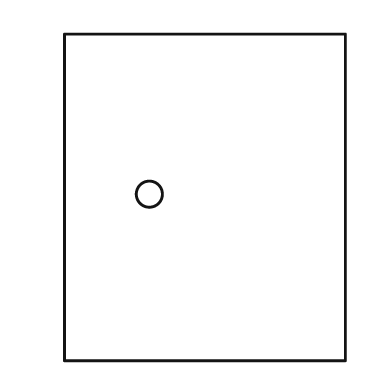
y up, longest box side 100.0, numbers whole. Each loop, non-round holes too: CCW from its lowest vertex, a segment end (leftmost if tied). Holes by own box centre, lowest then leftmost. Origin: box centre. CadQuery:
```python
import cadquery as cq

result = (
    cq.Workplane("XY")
    .moveTo(-43.0, -50.0)
    .lineTo(43.0, -50.0)
    .lineTo(43.0, 50.0)
    .lineTo(-43.0, 50.0)
    .close()
    .moveTo(-17.0, 1.0)
    .circle(4.0)
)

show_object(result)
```